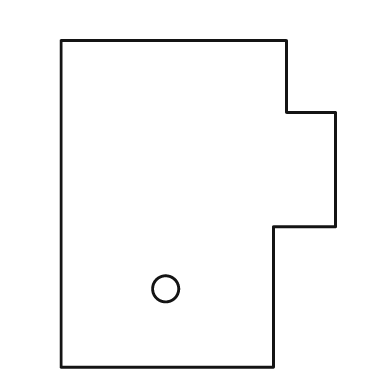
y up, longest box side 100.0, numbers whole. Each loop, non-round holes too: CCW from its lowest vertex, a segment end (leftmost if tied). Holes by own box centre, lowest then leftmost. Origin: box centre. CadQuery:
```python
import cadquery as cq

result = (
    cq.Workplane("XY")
    .moveTo(-42.0, -50.0)
    .lineTo(23.0, -50.0)
    .lineTo(23.0, -7.0)
    .lineTo(42.0, -7.0)
    .lineTo(42.0, 28.0)
    .lineTo(27.0, 28.0)
    .lineTo(27.0, 50.0)
    .lineTo(-42.0, 50.0)
    .close()
    .moveTo(-10.0, -26.0)
    .circle(4.0)
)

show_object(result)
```